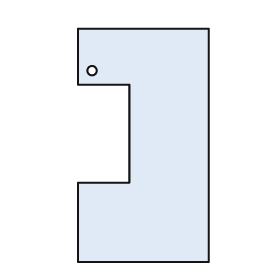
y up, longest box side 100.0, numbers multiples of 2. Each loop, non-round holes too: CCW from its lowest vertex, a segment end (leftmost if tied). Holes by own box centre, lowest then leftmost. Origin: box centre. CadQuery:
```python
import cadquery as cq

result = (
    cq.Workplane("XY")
    .moveTo(-28.0, -50.0)
    .lineTo(28.0, -50.0)
    .lineTo(28.0, 50.0)
    .lineTo(-28.0, 50.0)
    .lineTo(-28.0, 26.0)
    .lineTo(-6.0, 26.0)
    .lineTo(-6.0, -16.0)
    .lineTo(-28.0, -16.0)
    .close()
    .moveTo(-22.0, 32.0)
    .circle(2.0)
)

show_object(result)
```